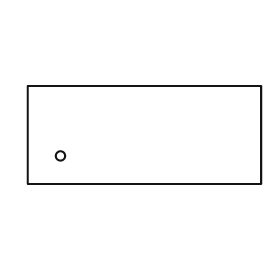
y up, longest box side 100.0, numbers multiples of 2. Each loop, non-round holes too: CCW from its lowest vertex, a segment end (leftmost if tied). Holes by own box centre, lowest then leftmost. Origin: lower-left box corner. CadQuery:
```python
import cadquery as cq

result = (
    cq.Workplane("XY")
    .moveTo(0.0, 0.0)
    .lineTo(100.0, 0.0)
    .lineTo(100.0, 42.0)
    .lineTo(0.0, 42.0)
    .close()
    .moveTo(14.0, 12.0)
    .circle(2.0)
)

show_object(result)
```